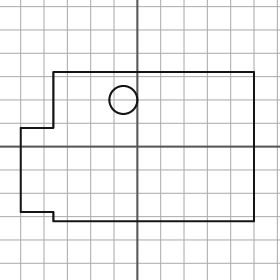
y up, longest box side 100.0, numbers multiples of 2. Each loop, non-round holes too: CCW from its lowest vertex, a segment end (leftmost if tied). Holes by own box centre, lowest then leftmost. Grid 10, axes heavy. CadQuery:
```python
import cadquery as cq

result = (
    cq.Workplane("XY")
    .moveTo(-36.0, -32.0)
    .lineTo(50.0, -32.0)
    .lineTo(50.0, 32.0)
    .lineTo(-36.0, 32.0)
    .lineTo(-36.0, 8.0)
    .lineTo(-50.0, 8.0)
    .lineTo(-50.0, -28.0)
    .lineTo(-36.0, -28.0)
    .close()
    .moveTo(-6.0, 20.0)
    .circle(6.0)
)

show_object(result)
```